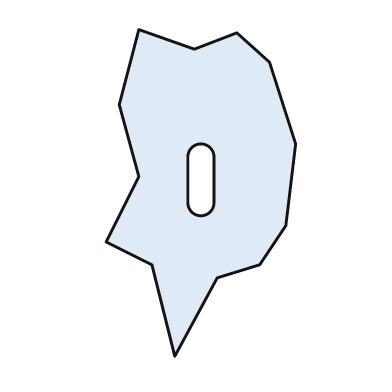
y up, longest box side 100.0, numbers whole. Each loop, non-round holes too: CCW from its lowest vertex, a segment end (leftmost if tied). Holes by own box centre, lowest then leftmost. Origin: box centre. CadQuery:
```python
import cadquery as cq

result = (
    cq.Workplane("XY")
    .moveTo(-8.0, -50.0)
    .lineTo(5.0, -26.0)
    .lineTo(18.0, -22.0)
    .lineTo(26.0, -10.0)
    .lineTo(29.0, 15.0)
    .lineTo(21.0, 40.0)
    .lineTo(11.0, 49.0)
    .lineTo(-2.0, 44.0)
    .lineTo(-19.0, 50.0)
    .lineTo(-25.0, 27.0)
    .lineTo(-19.0, 5.0)
    .lineTo(-29.0, -15.0)
    .lineTo(-15.0, -22.0)
    .close()
    .moveTo(-4.0, -3.0)
    .threePointArc((0.0, -7.0), (4.0, -3.0))
    .lineTo(4.0, 11.0)
    .threePointArc((0.0, 15.0), (-4.0, 11.0))
    .close()
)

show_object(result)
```